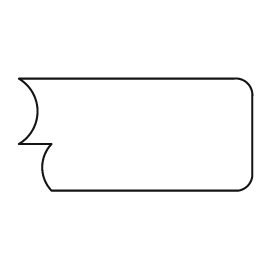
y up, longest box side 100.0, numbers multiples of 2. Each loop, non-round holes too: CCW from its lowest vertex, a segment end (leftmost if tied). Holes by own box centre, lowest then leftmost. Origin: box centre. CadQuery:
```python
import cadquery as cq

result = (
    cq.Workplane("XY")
    .moveTo(-36.0, -24.0)
    .lineTo(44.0, -24.0)
    .threePointArc((48.0, -22.0), (50.0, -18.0))
    .lineTo(50.0, 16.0)
    .threePointArc((48.0, 22.0), (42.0, 24.0))
    .lineTo(-50.0, 24.0)
    .threePointArc((-42.0, 10.0), (-50.0, -4.0))
    .lineTo(-36.0, -4.0)
    .threePointArc((-40.0, -14.0), (-36.0, -24.0))
    .close()
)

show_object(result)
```